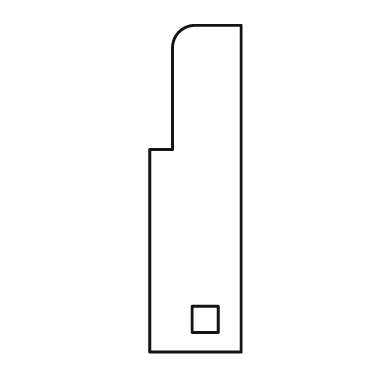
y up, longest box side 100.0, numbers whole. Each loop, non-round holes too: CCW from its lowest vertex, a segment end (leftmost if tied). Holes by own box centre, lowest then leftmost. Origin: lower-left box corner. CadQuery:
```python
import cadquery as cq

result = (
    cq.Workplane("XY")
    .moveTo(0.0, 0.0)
    .lineTo(28.0, 0.0)
    .lineTo(28.0, 100.0)
    .lineTo(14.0, 100.0)
    .threePointArc((9.0, 98.0), (7.0, 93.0))
    .lineTo(7.0, 62.0)
    .lineTo(0.0, 62.0)
    .close()
    .moveTo(13.0, 6.0)
    .lineTo(21.0, 6.0)
    .lineTo(21.0, 14.0)
    .lineTo(13.0, 14.0)
    .close()
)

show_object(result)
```